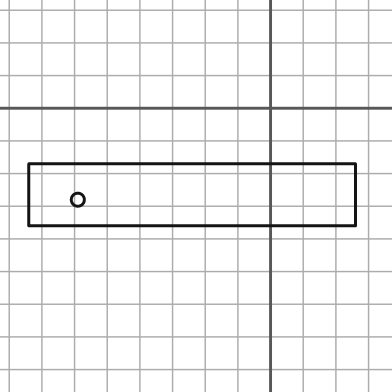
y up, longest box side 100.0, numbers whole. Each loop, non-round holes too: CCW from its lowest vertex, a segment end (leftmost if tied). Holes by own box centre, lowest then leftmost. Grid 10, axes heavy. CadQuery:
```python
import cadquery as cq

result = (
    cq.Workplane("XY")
    .moveTo(-74.0, -36.0)
    .lineTo(26.0, -36.0)
    .lineTo(26.0, -17.0)
    .lineTo(-74.0, -17.0)
    .close()
    .moveTo(-59.0, -28.0)
    .circle(2.0)
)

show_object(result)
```